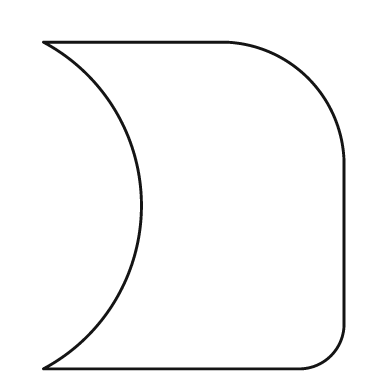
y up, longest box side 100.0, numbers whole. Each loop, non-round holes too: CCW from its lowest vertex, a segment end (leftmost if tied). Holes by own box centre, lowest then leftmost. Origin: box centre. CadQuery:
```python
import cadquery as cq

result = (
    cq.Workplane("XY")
    .moveTo(-46.0, -50.0)
    .lineTo(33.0, -50.0)
    .threePointArc((42.0, -46.0), (46.0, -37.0))
    .lineTo(46.0, 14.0)
    .threePointArc((35.0, 39.0), (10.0, 50.0))
    .lineTo(-46.0, 50.0)
    .threePointArc((-16.0, 0.0), (-46.0, -50.0))
    .close()
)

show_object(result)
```